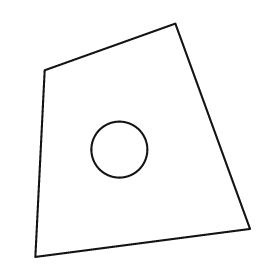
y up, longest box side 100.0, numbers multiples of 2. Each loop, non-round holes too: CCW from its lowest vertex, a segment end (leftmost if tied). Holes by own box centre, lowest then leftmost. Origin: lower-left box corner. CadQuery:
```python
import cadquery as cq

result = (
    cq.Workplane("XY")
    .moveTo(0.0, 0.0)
    .lineTo(92.0, 12.0)
    .lineTo(60.0, 100.0)
    .lineTo(4.0, 80.0)
    .close()
    .moveTo(36.0, 46.0)
    .circle(12.0)
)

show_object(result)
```